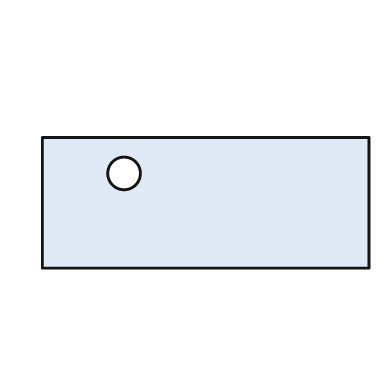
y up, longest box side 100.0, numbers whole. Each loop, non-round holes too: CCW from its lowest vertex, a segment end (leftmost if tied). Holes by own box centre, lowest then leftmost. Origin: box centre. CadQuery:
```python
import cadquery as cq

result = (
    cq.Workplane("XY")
    .moveTo(-50.0, -20.0)
    .lineTo(50.0, -20.0)
    .lineTo(50.0, 20.0)
    .lineTo(-50.0, 20.0)
    .close()
    .moveTo(-25.0, 9.0)
    .circle(5.0)
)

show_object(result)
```